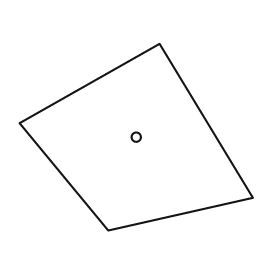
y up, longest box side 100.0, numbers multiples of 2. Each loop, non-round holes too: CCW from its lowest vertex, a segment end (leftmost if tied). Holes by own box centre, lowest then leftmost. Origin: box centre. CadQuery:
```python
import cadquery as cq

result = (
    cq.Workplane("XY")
    .moveTo(-12.0, -40.0)
    .lineTo(50.0, -26.0)
    .lineTo(10.0, 40.0)
    .lineTo(-50.0, 6.0)
    .close()
    .moveTo(0.0, 0.0)
    .circle(2.0)
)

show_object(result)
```